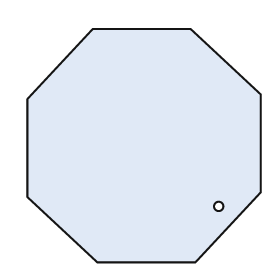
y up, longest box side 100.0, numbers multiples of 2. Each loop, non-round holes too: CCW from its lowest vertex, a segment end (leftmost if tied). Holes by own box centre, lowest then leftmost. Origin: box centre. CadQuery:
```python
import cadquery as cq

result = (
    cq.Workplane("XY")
    .moveTo(-20.0, -50.0)
    .lineTo(22.0, -50.0)
    .lineTo(50.0, -20.0)
    .lineTo(50.0, 22.0)
    .lineTo(20.0, 50.0)
    .lineTo(-22.0, 50.0)
    .lineTo(-50.0, 20.0)
    .lineTo(-50.0, -22.0)
    .close()
    .moveTo(32.0, -26.0)
    .circle(2.0)
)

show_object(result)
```